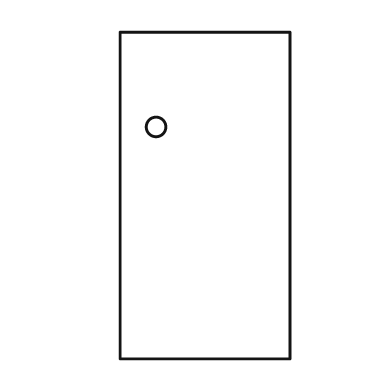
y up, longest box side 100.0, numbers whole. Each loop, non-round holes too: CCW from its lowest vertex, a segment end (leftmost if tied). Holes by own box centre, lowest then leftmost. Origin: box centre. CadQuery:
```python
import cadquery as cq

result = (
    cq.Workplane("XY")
    .moveTo(-26.0, -50.0)
    .lineTo(26.0, -50.0)
    .lineTo(26.0, 50.0)
    .lineTo(-26.0, 50.0)
    .close()
    .moveTo(-15.0, 21.0)
    .circle(3.0)
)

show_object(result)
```